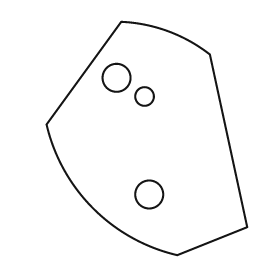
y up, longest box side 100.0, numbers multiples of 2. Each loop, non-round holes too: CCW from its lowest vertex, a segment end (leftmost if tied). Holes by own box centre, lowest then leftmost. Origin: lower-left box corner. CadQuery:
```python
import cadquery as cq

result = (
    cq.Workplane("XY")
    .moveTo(56.0, 0.0)
    .lineTo(86.0, 12.0)
    .lineTo(70.0, 86.0)
    .threePointArc((52.0, 96.0), (32.0, 100.0))
    .lineTo(0.0, 56.0)
    .threePointArc((20.0, 20.0), (56.0, 0.0))
    .close()
    .moveTo(44.0, 26.0)
    .circle(6.0)
    .moveTo(42.0, 68.0)
    .circle(4.0)
    .moveTo(30.0, 76.0)
    .circle(6.0)
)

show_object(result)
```